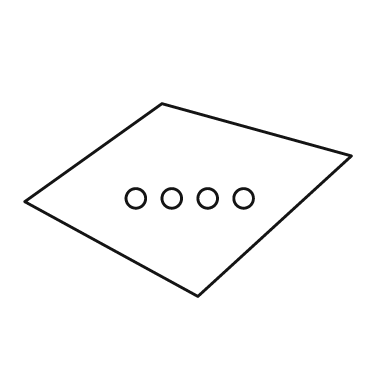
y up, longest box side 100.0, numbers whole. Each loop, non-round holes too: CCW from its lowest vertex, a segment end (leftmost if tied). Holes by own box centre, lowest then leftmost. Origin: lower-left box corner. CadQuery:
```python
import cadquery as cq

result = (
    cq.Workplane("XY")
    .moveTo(53.0, 0.0)
    .lineTo(100.0, 43.0)
    .lineTo(42.0, 59.0)
    .lineTo(0.0, 29.0)
    .close()
    .moveTo(34.0, 30.0)
    .circle(3.0)
    .moveTo(45.0, 30.0)
    .circle(3.0)
    .moveTo(56.0, 30.0)
    .circle(3.0)
    .moveTo(67.0, 30.0)
    .circle(3.0)
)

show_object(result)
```